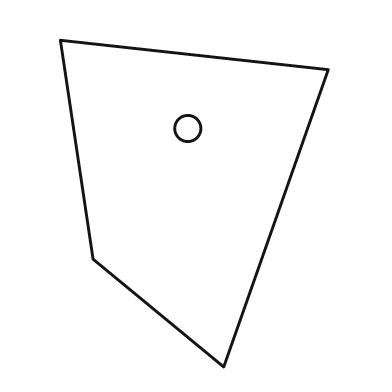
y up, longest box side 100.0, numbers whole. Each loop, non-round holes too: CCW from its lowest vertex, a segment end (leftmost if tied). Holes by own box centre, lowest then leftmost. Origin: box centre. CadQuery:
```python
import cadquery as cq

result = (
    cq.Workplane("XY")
    .moveTo(9.0, -50.0)
    .lineTo(41.0, 41.0)
    .lineTo(-41.0, 50.0)
    .lineTo(-31.0, -17.0)
    .close()
    .moveTo(-2.0, 23.0)
    .circle(4.0)
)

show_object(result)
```